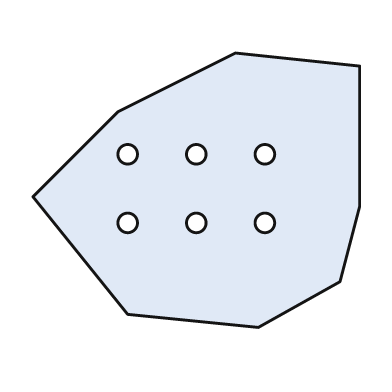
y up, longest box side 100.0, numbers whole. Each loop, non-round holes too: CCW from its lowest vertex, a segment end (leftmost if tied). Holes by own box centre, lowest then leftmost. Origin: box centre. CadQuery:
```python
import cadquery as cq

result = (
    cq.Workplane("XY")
    .moveTo(19.0, -42.0)
    .lineTo(44.0, -28.0)
    .lineTo(50.0, -5.0)
    .lineTo(50.0, 38.0)
    .lineTo(12.0, 42.0)
    .lineTo(-24.0, 24.0)
    .lineTo(-50.0, -2.0)
    .lineTo(-21.0, -38.0)
    .close()
    .moveTo(-21.0, -10.0)
    .circle(3.0)
    .moveTo(0.0, -10.0)
    .circle(3.0)
    .moveTo(21.0, -10.0)
    .circle(3.0)
    .moveTo(-21.0, 11.0)
    .circle(3.0)
    .moveTo(0.0, 11.0)
    .circle(3.0)
    .moveTo(21.0, 11.0)
    .circle(3.0)
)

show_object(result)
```